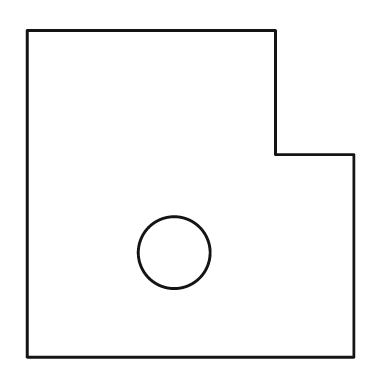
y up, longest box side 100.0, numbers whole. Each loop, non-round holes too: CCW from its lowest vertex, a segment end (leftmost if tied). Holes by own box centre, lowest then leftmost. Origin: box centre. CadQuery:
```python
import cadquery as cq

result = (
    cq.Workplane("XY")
    .moveTo(-50.0, -50.0)
    .lineTo(50.0, -50.0)
    .lineTo(50.0, 12.0)
    .lineTo(26.0, 12.0)
    .lineTo(26.0, 50.0)
    .lineTo(-50.0, 50.0)
    .close()
    .moveTo(-5.0, -18.0)
    .circle(11.0)
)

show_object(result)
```